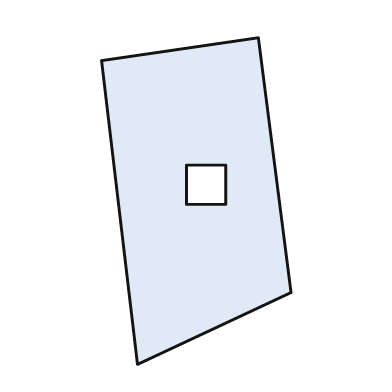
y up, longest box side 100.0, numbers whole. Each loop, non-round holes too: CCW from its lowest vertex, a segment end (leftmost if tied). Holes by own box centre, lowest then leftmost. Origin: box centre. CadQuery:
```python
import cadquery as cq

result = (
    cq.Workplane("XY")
    .moveTo(-18.0, -50.0)
    .lineTo(29.0, -28.0)
    .lineTo(19.0, 50.0)
    .lineTo(-29.0, 43.0)
    .close()
    .moveTo(-3.0, -1.0)
    .lineTo(9.0, -1.0)
    .lineTo(9.0, 11.0)
    .lineTo(-3.0, 11.0)
    .close()
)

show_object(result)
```